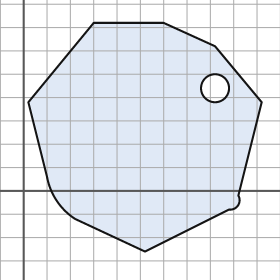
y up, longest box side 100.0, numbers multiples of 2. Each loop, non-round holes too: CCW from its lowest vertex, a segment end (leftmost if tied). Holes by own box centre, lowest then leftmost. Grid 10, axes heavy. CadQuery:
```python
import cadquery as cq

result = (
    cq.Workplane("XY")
    .moveTo(52.0, -26.0)
    .lineTo(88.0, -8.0)
    .threePointArc((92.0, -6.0), (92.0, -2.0))
    .lineTo(102.0, 38.0)
    .lineTo(82.0, 62.0)
    .lineTo(60.0, 72.0)
    .lineTo(30.0, 72.0)
    .lineTo(2.0, 38.0)
    .lineTo(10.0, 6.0)
    .threePointArc((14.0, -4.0), (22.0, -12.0))
    .close()
    .moveTo(82.0, 44.0)
    .circle(6.0)
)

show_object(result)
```